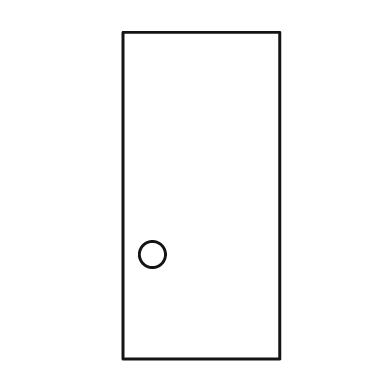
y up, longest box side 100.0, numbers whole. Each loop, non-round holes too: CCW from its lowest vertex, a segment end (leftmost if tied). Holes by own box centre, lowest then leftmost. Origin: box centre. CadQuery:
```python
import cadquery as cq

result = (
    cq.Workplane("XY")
    .moveTo(-24.0, -50.0)
    .lineTo(24.0, -50.0)
    .lineTo(24.0, 50.0)
    .lineTo(-24.0, 50.0)
    .close()
    .moveTo(-15.0, -18.0)
    .circle(4.0)
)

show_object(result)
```